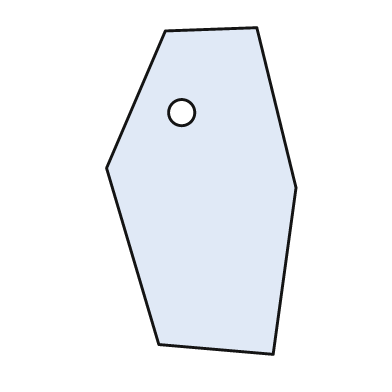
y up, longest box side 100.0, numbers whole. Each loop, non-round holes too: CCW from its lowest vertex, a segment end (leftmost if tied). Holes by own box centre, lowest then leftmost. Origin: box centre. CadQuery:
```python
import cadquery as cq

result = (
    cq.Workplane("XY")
    .moveTo(22.0, -50.0)
    .lineTo(29.0, 1.0)
    .lineTo(17.0, 50.0)
    .lineTo(-11.0, 49.0)
    .lineTo(-29.0, 7.0)
    .lineTo(-13.0, -47.0)
    .close()
    .moveTo(-6.0, 24.0)
    .circle(4.0)
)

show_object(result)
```